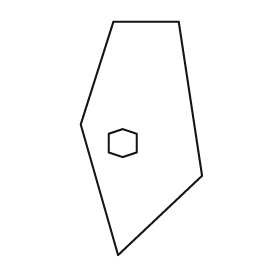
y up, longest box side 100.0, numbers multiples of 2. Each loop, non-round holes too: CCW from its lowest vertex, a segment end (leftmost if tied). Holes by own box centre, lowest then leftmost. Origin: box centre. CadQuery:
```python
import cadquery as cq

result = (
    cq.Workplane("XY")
    .moveTo(-10.0, -50.0)
    .lineTo(26.0, -16.0)
    .lineTo(16.0, 50.0)
    .lineTo(-12.0, 50.0)
    .lineTo(-26.0, 6.0)
    .close()
    .moveTo(-8.0, -8.0)
    .lineTo(-2.0, -6.0)
    .lineTo(-2.0, 2.0)
    .lineTo(-8.0, 4.0)
    .lineTo(-14.0, 2.0)
    .lineTo(-14.0, -6.0)
    .close()
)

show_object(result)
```